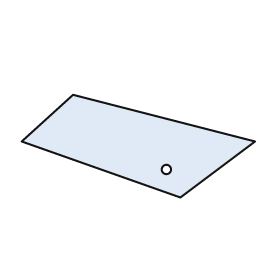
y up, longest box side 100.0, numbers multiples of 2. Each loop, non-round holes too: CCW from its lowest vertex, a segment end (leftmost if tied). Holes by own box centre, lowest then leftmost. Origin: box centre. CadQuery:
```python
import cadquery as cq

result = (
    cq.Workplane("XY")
    .moveTo(18.0, -22.0)
    .lineTo(50.0, 2.0)
    .lineTo(-28.0, 22.0)
    .lineTo(-50.0, 2.0)
    .close()
    .moveTo(12.0, -10.0)
    .circle(2.0)
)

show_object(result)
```